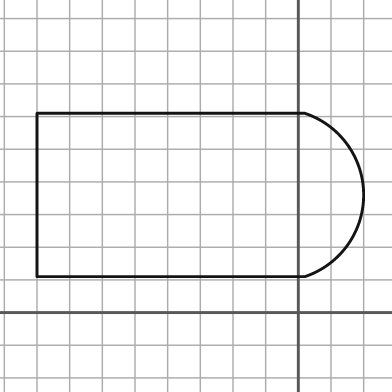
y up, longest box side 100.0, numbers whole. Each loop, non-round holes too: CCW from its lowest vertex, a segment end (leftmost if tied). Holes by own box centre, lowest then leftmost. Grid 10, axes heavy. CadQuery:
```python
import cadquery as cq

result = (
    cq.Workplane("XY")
    .moveTo(-80.0, 11.0)
    .lineTo(2.0, 11.0)
    .threePointArc((20.0, 36.0), (2.0, 61.0))
    .lineTo(-80.0, 61.0)
    .close()
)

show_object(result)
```